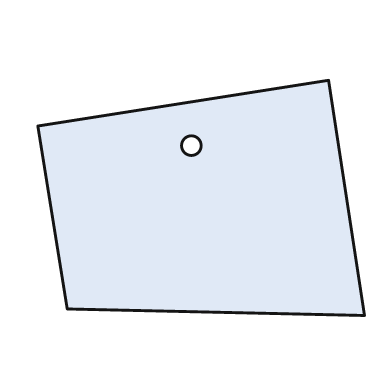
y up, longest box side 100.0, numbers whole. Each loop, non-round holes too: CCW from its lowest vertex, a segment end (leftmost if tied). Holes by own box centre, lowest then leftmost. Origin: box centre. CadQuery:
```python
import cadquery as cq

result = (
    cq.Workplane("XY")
    .moveTo(50.0, -36.0)
    .lineTo(39.0, 36.0)
    .lineTo(-50.0, 22.0)
    .lineTo(-41.0, -34.0)
    .close()
    .moveTo(-3.0, 16.0)
    .circle(3.0)
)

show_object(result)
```